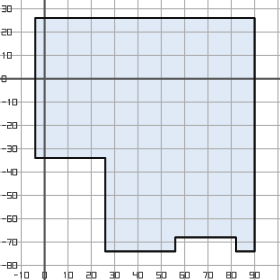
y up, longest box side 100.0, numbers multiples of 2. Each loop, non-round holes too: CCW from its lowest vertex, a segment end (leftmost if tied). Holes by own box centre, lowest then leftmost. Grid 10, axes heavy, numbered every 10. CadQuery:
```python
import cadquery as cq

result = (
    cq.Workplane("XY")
    .moveTo(26.0, -74.0)
    .lineTo(56.0, -74.0)
    .lineTo(56.0, -68.0)
    .lineTo(82.0, -68.0)
    .lineTo(82.0, -74.0)
    .lineTo(90.0, -74.0)
    .lineTo(90.0, 26.0)
    .lineTo(-4.0, 26.0)
    .lineTo(-4.0, -34.0)
    .lineTo(26.0, -34.0)
    .close()
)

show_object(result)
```